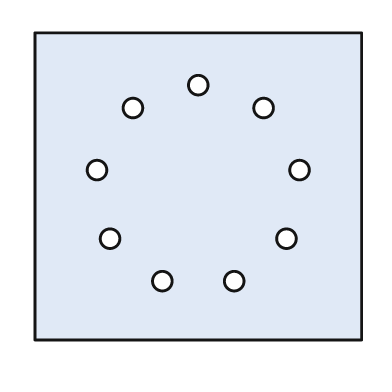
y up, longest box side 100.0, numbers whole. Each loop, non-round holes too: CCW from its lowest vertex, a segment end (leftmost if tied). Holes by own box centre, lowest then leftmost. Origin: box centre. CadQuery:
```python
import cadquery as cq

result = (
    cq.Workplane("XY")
    .moveTo(-50.0, -47.0)
    .lineTo(50.0, -47.0)
    .lineTo(50.0, 47.0)
    .lineTo(-50.0, 47.0)
    .close()
    .moveTo(-11.0, -29.0)
    .circle(3.0)
    .moveTo(11.0, -29.0)
    .circle(3.0)
    .moveTo(-27.0, -16.0)
    .circle(3.0)
    .moveTo(27.0, -16.0)
    .circle(3.0)
    .moveTo(-31.0, 5.0)
    .circle(3.0)
    .moveTo(31.0, 5.0)
    .circle(3.0)
    .moveTo(-20.0, 24.0)
    .circle(3.0)
    .moveTo(20.0, 24.0)
    .circle(3.0)
    .moveTo(0.0, 31.0)
    .circle(3.0)
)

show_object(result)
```